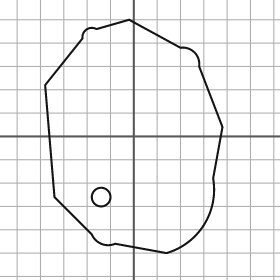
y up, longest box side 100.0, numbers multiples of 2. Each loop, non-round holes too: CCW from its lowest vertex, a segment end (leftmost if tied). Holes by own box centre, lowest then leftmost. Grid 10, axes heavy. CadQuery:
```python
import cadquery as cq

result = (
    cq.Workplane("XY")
    .moveTo(14.0, -50.0)
    .threePointArc((30.0, -38.0), (34.0, -18.0))
    .lineTo(38.0, 4.0)
    .lineTo(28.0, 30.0)
    .threePointArc((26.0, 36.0), (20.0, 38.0))
    .lineTo(-2.0, 50.0)
    .lineTo(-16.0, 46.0)
    .threePointArc((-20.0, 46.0), (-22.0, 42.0))
    .lineTo(-38.0, 22.0)
    .lineTo(-34.0, -26.0)
    .lineTo(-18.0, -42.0)
    .threePointArc((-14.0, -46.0), (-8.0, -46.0))
    .close()
    .moveTo(-14.0, -26.0)
    .circle(4.0)
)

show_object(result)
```